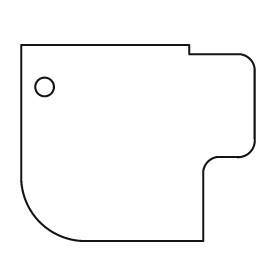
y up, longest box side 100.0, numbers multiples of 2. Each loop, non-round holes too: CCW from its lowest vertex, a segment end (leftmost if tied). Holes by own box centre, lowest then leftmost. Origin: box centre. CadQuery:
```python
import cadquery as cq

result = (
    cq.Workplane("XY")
    .moveTo(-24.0, -42.0)
    .lineTo(28.0, -42.0)
    .lineTo(28.0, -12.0)
    .threePointArc((30.0, -8.0), (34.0, -6.0))
    .lineTo(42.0, -6.0)
    .threePointArc((48.0, -4.0), (50.0, 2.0))
    .lineTo(50.0, 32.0)
    .threePointArc((48.0, 36.0), (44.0, 38.0))
    .lineTo(22.0, 38.0)
    .lineTo(22.0, 42.0)
    .lineTo(-50.0, 42.0)
    .lineTo(-50.0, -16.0)
    .threePointArc((-42.0, -34.0), (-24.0, -42.0))
    .close()
    .moveTo(-40.0, 24.0)
    .circle(4.0)
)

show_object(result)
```